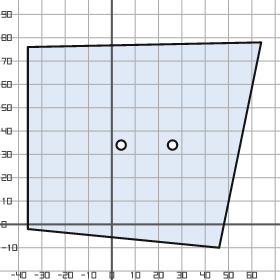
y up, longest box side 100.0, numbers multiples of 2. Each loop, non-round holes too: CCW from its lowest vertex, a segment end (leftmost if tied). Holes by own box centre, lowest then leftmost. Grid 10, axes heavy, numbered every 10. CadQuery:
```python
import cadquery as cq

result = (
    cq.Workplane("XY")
    .moveTo(46.0, -10.0)
    .lineTo(64.0, 78.0)
    .lineTo(-36.0, 76.0)
    .lineTo(-36.0, -2.0)
    .close()
    .moveTo(4.0, 34.0)
    .circle(2.0)
    .moveTo(26.0, 34.0)
    .circle(2.0)
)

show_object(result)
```